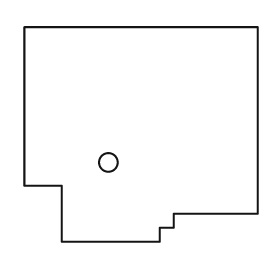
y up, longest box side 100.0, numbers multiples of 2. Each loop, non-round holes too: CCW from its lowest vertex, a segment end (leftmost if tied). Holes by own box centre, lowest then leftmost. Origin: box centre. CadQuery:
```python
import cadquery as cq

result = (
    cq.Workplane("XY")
    .moveTo(-34.0, -46.0)
    .lineTo(8.0, -46.0)
    .lineTo(8.0, -40.0)
    .lineTo(14.0, -40.0)
    .lineTo(14.0, -34.0)
    .lineTo(50.0, -34.0)
    .lineTo(50.0, 46.0)
    .lineTo(-50.0, 46.0)
    .lineTo(-50.0, -22.0)
    .lineTo(-34.0, -22.0)
    .close()
    .moveTo(-14.0, -12.0)
    .circle(4.0)
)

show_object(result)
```